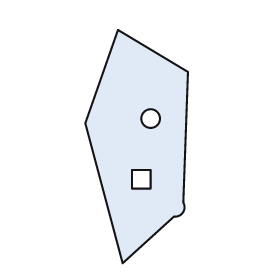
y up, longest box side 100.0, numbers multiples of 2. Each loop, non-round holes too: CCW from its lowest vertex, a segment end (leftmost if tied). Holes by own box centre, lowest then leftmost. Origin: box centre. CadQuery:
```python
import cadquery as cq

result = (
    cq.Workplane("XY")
    .moveTo(-6.0, -50.0)
    .lineTo(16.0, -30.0)
    .threePointArc((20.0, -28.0), (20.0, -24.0))
    .lineTo(22.0, 32.0)
    .lineTo(-8.0, 50.0)
    .lineTo(-22.0, 10.0)
    .close()
    .moveTo(-2.0, -18.0)
    .lineTo(6.0, -18.0)
    .lineTo(6.0, -10.0)
    .lineTo(-2.0, -10.0)
    .close()
    .moveTo(6.0, 12.0)
    .circle(4.0)
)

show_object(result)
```